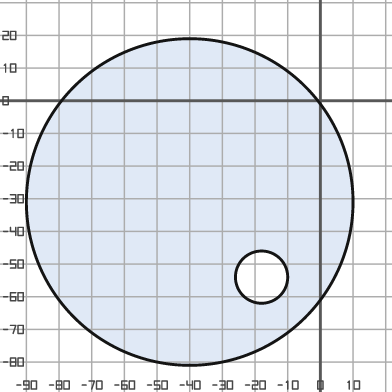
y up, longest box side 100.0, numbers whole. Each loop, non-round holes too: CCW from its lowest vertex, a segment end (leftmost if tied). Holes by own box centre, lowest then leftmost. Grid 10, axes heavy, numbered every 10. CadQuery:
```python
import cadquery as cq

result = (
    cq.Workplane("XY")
    .moveTo(-40.0, -31.0)
    .circle(50.0)
    .moveTo(-18.0, -54.0)
    .circle(8.0)
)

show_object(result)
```